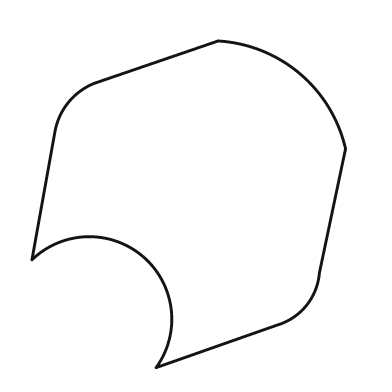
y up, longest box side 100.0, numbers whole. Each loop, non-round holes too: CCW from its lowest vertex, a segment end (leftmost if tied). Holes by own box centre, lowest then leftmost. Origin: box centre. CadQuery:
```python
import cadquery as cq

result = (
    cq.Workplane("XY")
    .moveTo(-10.0, -50.0)
    .lineTo(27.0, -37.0)
    .threePointArc((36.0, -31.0), (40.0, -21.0))
    .lineTo(48.0, 17.0)
    .threePointArc((34.0, 40.0), (9.0, 50.0))
    .lineTo(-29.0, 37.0)
    .threePointArc((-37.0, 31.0), (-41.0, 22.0))
    .lineTo(-48.0, -17.0)
    .threePointArc((-14.0, -16.0), (-10.0, -50.0))
    .close()
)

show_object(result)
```